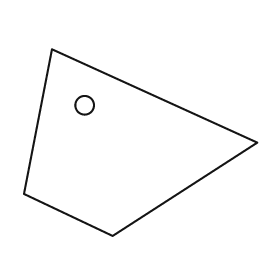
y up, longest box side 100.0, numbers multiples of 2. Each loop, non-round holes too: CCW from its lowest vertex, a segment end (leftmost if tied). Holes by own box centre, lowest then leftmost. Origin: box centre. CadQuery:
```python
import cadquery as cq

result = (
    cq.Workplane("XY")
    .moveTo(-12.0, -40.0)
    .lineTo(50.0, 0.0)
    .lineTo(-38.0, 40.0)
    .lineTo(-50.0, -22.0)
    .close()
    .moveTo(-24.0, 16.0)
    .circle(4.0)
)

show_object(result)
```